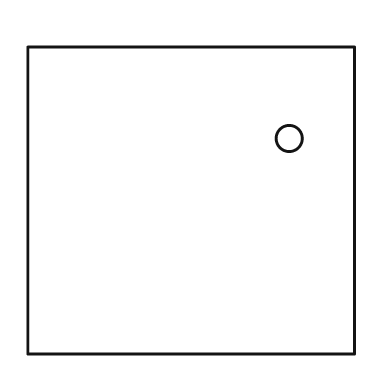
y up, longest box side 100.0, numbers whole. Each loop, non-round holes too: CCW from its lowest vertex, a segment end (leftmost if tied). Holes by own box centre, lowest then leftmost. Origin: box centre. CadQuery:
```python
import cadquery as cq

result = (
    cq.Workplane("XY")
    .moveTo(-50.0, -47.0)
    .lineTo(50.0, -47.0)
    .lineTo(50.0, 47.0)
    .lineTo(-50.0, 47.0)
    .close()
    .moveTo(30.0, 19.0)
    .circle(4.0)
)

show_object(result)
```